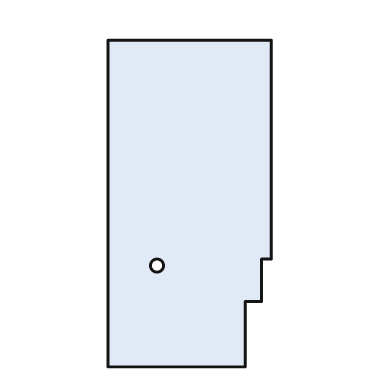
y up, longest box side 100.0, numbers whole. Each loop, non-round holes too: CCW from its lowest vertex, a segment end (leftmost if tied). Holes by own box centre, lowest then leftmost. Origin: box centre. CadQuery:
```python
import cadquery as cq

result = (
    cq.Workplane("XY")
    .moveTo(-25.0, -50.0)
    .lineTo(17.0, -50.0)
    .lineTo(17.0, -30.0)
    .lineTo(22.0, -30.0)
    .lineTo(22.0, -17.0)
    .lineTo(25.0, -17.0)
    .lineTo(25.0, 50.0)
    .lineTo(-25.0, 50.0)
    .close()
    .moveTo(-10.0, -19.0)
    .circle(2.0)
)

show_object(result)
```